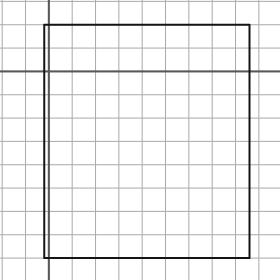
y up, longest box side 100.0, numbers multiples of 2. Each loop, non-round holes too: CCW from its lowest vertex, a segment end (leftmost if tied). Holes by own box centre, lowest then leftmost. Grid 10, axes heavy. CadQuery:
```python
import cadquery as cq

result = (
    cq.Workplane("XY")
    .moveTo(-2.0, -80.0)
    .lineTo(86.0, -80.0)
    .lineTo(86.0, 20.0)
    .lineTo(-2.0, 20.0)
    .close()
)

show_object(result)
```